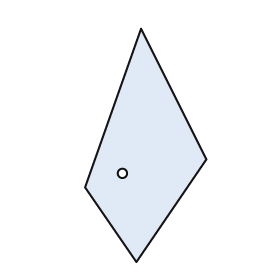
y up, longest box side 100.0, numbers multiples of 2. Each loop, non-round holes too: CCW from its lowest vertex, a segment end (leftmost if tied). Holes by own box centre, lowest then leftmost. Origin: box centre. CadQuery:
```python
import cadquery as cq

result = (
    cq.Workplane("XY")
    .moveTo(-4.0, -50.0)
    .lineTo(26.0, -6.0)
    .lineTo(-2.0, 50.0)
    .lineTo(-26.0, -18.0)
    .close()
    .moveTo(-10.0, -12.0)
    .circle(2.0)
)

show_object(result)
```